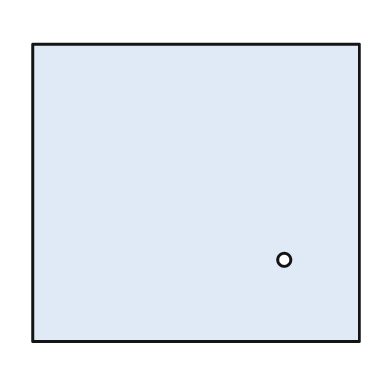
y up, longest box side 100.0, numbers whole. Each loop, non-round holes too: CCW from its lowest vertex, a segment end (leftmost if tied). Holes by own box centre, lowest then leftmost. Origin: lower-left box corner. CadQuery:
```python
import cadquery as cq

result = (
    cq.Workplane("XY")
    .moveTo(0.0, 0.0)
    .lineTo(100.0, 0.0)
    .lineTo(100.0, 91.0)
    .lineTo(0.0, 91.0)
    .close()
    .moveTo(77.0, 25.0)
    .circle(2.0)
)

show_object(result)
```